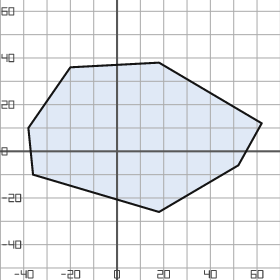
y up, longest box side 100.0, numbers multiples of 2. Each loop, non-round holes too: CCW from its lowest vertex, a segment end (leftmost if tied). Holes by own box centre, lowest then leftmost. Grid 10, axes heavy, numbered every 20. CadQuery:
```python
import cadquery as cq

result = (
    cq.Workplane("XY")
    .moveTo(18.0, -26.0)
    .lineTo(52.0, -6.0)
    .lineTo(62.0, 12.0)
    .lineTo(18.0, 38.0)
    .lineTo(-20.0, 36.0)
    .lineTo(-38.0, 10.0)
    .lineTo(-36.0, -10.0)
    .close()
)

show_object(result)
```